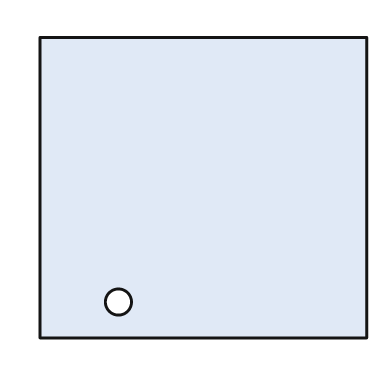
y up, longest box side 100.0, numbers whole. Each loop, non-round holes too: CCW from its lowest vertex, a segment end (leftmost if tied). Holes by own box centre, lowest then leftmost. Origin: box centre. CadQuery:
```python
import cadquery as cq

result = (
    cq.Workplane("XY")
    .moveTo(-50.0, -46.0)
    .lineTo(50.0, -46.0)
    .lineTo(50.0, 46.0)
    .lineTo(-50.0, 46.0)
    .close()
    .moveTo(-26.0, -35.0)
    .circle(4.0)
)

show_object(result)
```